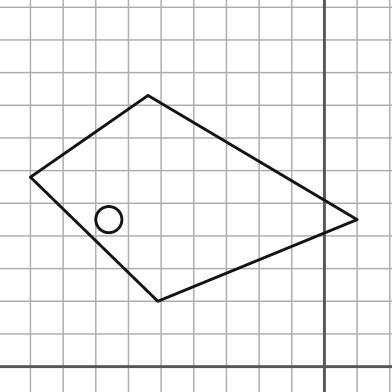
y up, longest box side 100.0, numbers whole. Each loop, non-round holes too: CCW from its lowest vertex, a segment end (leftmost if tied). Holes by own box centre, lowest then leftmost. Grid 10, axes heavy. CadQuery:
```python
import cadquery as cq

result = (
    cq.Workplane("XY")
    .moveTo(-51.0, 20.0)
    .lineTo(10.0, 45.0)
    .lineTo(-54.0, 83.0)
    .lineTo(-90.0, 58.0)
    .close()
    .moveTo(-66.0, 45.0)
    .circle(4.0)
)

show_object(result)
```